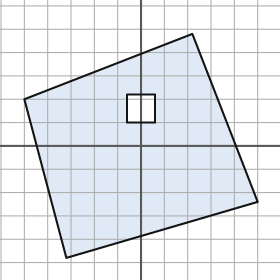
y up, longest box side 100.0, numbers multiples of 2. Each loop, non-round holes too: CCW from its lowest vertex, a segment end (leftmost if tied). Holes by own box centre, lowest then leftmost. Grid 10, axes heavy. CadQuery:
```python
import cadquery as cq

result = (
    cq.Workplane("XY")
    .moveTo(-32.0, -48.0)
    .lineTo(50.0, -24.0)
    .lineTo(22.0, 48.0)
    .lineTo(-50.0, 20.0)
    .close()
    .moveTo(-6.0, 10.0)
    .lineTo(6.0, 10.0)
    .lineTo(6.0, 22.0)
    .lineTo(-6.0, 22.0)
    .close()
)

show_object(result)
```